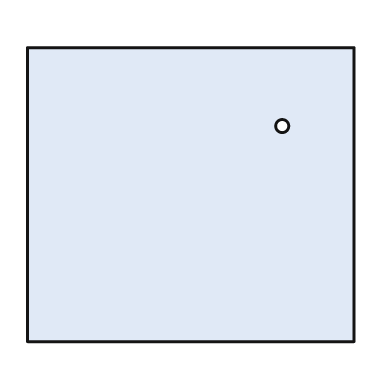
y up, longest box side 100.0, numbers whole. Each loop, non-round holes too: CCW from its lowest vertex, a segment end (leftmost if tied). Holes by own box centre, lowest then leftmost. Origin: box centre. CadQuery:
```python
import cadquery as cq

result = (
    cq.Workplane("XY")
    .moveTo(-50.0, -45.0)
    .lineTo(50.0, -45.0)
    .lineTo(50.0, 45.0)
    .lineTo(-50.0, 45.0)
    .close()
    .moveTo(28.0, 21.0)
    .circle(2.0)
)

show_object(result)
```